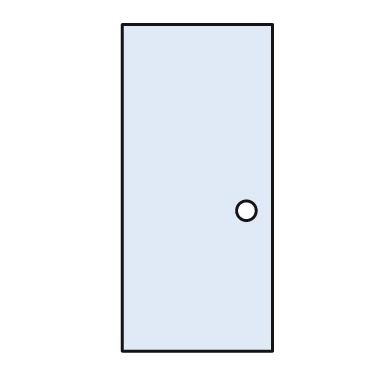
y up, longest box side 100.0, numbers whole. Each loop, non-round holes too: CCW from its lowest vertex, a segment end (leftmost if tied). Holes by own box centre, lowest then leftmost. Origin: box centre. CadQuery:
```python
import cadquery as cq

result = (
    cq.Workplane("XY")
    .moveTo(-23.0, -50.0)
    .lineTo(23.0, -50.0)
    .lineTo(23.0, 50.0)
    .lineTo(-23.0, 50.0)
    .close()
    .moveTo(15.0, -7.0)
    .circle(3.0)
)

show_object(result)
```